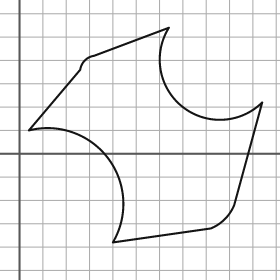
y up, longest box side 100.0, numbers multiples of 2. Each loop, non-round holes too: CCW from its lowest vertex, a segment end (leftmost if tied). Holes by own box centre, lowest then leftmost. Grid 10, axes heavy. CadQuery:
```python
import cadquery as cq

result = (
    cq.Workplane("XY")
    .moveTo(40.0, -38.0)
    .lineTo(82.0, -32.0)
    .threePointArc((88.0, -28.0), (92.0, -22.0))
    .lineTo(104.0, 22.0)
    .threePointArc((70.0, 20.0), (64.0, 54.0))
    .lineTo(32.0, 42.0)
    .threePointArc((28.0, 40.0), (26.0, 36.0))
    .lineTo(4.0, 10.0)
    .threePointArc((38.0, -2.0), (40.0, -38.0))
    .close()
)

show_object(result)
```